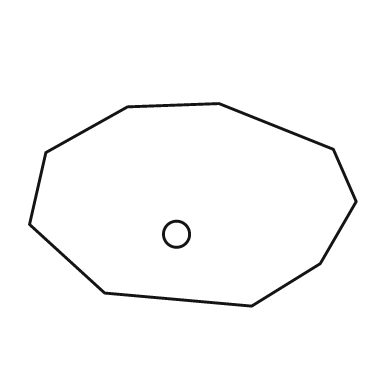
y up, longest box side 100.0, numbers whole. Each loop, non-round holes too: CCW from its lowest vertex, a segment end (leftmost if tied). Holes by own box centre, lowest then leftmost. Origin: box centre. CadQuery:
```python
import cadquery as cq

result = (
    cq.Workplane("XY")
    .moveTo(18.0, -31.0)
    .lineTo(39.0, -18.0)
    .lineTo(50.0, 1.0)
    .lineTo(43.0, 17.0)
    .lineTo(8.0, 31.0)
    .lineTo(-20.0, 30.0)
    .lineTo(-45.0, 16.0)
    .lineTo(-50.0, -6.0)
    .lineTo(-27.0, -27.0)
    .close()
    .moveTo(-5.0, -9.0)
    .circle(4.0)
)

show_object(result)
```